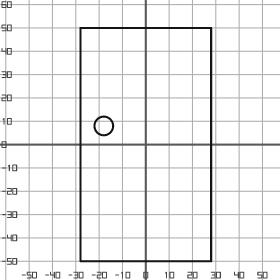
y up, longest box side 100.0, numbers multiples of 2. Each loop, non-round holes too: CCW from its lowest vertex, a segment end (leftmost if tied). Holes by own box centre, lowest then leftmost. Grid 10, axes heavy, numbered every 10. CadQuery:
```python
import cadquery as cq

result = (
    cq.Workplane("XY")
    .moveTo(-28.0, -50.0)
    .lineTo(28.0, -50.0)
    .lineTo(28.0, 50.0)
    .lineTo(-28.0, 50.0)
    .close()
    .moveTo(-18.0, 8.0)
    .circle(4.0)
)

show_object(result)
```